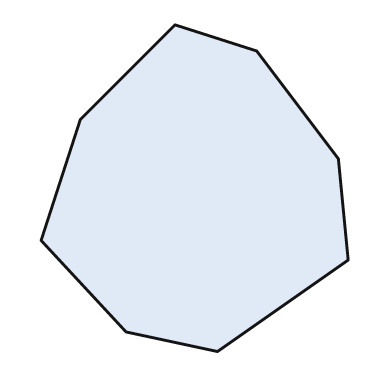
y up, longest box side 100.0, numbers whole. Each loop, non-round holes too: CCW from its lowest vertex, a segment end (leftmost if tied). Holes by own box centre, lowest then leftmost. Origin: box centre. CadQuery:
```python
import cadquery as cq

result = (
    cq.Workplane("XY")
    .moveTo(7.0, -50.0)
    .lineTo(47.0, -22.0)
    .lineTo(44.0, 9.0)
    .lineTo(19.0, 42.0)
    .lineTo(-6.0, 50.0)
    .lineTo(-35.0, 21.0)
    .lineTo(-47.0, -16.0)
    .lineTo(-21.0, -44.0)
    .close()
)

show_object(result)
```